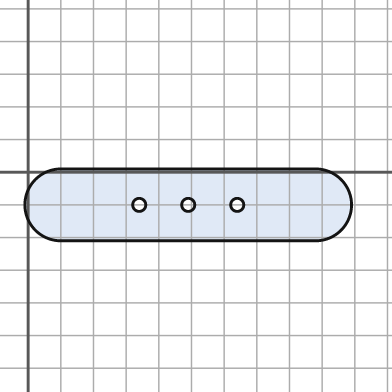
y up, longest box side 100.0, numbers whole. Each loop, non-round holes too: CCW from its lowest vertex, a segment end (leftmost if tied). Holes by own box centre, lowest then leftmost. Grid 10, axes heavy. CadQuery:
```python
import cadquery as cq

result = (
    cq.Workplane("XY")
    .moveTo(10.0, -21.0)
    .lineTo(88.0, -21.0)
    .threePointArc((99.0, -10.0), (88.0, 1.0))
    .lineTo(10.0, 1.0)
    .threePointArc((-1.0, -10.0), (10.0, -21.0))
    .close()
    .moveTo(34.0, -10.0)
    .circle(2.0)
    .moveTo(49.0, -10.0)
    .circle(2.0)
    .moveTo(64.0, -10.0)
    .circle(2.0)
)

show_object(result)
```